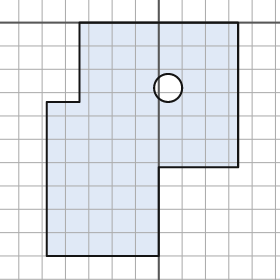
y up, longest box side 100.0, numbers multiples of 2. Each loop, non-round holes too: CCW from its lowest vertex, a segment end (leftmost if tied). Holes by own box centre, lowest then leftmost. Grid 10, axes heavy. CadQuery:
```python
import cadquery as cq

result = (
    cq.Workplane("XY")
    .moveTo(-48.0, -100.0)
    .lineTo(0.0, -100.0)
    .lineTo(0.0, -62.0)
    .lineTo(34.0, -62.0)
    .lineTo(34.0, 0.0)
    .lineTo(-34.0, 0.0)
    .lineTo(-34.0, -34.0)
    .lineTo(-48.0, -34.0)
    .close()
    .moveTo(4.0, -28.0)
    .circle(6.0)
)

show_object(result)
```